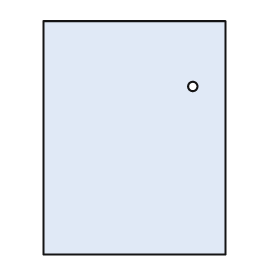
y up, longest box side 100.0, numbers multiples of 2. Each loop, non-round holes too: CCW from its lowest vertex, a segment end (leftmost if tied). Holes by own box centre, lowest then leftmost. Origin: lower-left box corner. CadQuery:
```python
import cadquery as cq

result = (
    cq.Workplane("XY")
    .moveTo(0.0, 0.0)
    .lineTo(78.0, 0.0)
    .lineTo(78.0, 100.0)
    .lineTo(0.0, 100.0)
    .close()
    .moveTo(64.0, 72.0)
    .circle(2.0)
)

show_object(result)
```